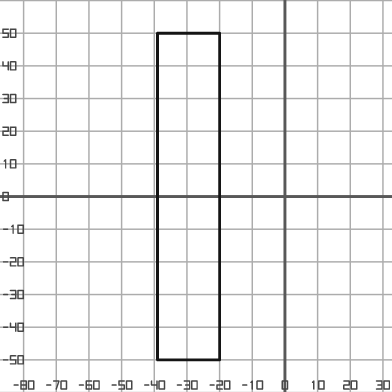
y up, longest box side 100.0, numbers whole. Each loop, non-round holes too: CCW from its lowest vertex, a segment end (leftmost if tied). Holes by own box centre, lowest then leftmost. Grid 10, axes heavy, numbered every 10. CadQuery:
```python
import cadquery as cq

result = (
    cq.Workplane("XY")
    .moveTo(-39.0, -50.0)
    .lineTo(-20.0, -50.0)
    .lineTo(-20.0, 50.0)
    .lineTo(-39.0, 50.0)
    .close()
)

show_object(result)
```